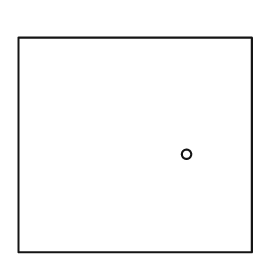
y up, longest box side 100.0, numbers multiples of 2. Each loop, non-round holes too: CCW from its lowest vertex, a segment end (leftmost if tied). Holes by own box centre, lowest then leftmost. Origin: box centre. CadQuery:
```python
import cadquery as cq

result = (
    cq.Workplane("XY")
    .moveTo(-50.0, -46.0)
    .lineTo(50.0, -46.0)
    .lineTo(50.0, 46.0)
    .lineTo(-50.0, 46.0)
    .close()
    .moveTo(22.0, -4.0)
    .circle(2.0)
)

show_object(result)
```